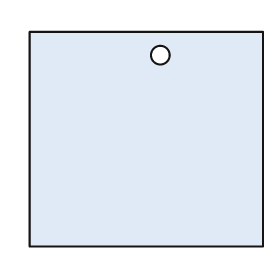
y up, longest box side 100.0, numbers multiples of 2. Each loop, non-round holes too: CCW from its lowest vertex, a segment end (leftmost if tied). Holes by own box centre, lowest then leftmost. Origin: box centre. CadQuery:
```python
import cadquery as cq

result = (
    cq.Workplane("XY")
    .moveTo(-50.0, -46.0)
    .lineTo(50.0, -46.0)
    .lineTo(50.0, 46.0)
    .lineTo(-50.0, 46.0)
    .close()
    .moveTo(6.0, 36.0)
    .circle(4.0)
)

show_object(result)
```